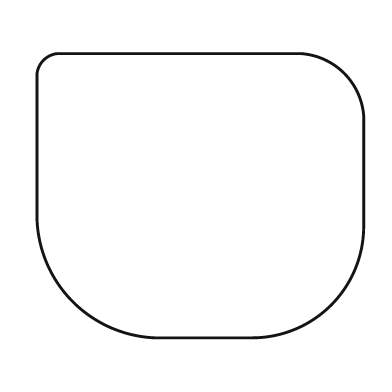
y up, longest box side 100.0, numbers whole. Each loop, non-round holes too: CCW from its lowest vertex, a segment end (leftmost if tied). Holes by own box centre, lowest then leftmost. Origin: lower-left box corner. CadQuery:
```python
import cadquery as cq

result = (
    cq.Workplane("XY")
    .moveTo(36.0, 0.0)
    .lineTo(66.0, 0.0)
    .threePointArc((90.0, 10.0), (100.0, 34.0))
    .lineTo(100.0, 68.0)
    .threePointArc((94.0, 81.0), (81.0, 87.0))
    .lineTo(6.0, 87.0)
    .threePointArc((2.0, 85.0), (0.0, 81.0))
    .lineTo(0.0, 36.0)
    .threePointArc((11.0, 11.0), (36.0, 0.0))
    .close()
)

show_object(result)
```